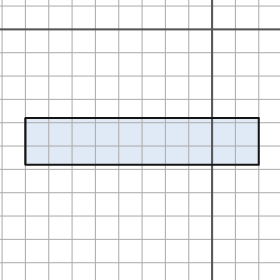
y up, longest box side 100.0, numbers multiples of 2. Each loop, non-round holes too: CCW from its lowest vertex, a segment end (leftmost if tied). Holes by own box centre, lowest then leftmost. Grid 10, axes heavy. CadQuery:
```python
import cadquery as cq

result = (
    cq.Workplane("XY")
    .moveTo(-80.0, -58.0)
    .lineTo(20.0, -58.0)
    .lineTo(20.0, -38.0)
    .lineTo(-80.0, -38.0)
    .close()
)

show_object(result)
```